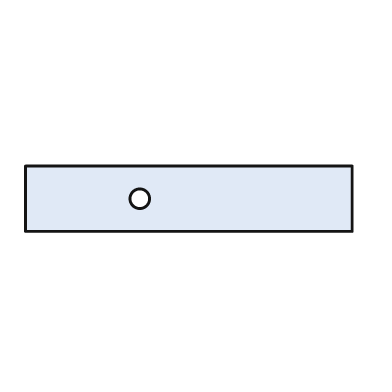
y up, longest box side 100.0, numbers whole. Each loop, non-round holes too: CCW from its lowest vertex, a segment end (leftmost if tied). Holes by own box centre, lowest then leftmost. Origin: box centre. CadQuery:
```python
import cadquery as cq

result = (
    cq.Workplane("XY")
    .moveTo(-50.0, -10.0)
    .lineTo(50.0, -10.0)
    .lineTo(50.0, 10.0)
    .lineTo(-50.0, 10.0)
    .close()
    .moveTo(-15.0, 0.0)
    .circle(3.0)
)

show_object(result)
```